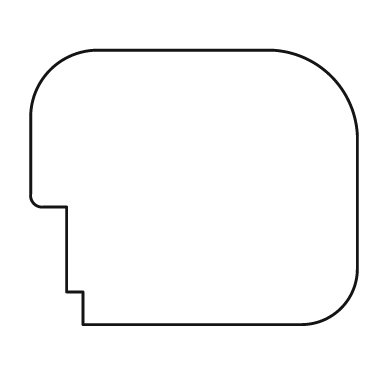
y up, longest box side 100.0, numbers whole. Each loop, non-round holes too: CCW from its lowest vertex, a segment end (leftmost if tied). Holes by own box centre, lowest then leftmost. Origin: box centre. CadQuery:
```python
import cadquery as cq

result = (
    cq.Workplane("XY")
    .moveTo(-34.0, -42.0)
    .lineTo(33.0, -42.0)
    .threePointArc((45.0, -37.0), (50.0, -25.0))
    .lineTo(50.0, 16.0)
    .threePointArc((42.0, 34.0), (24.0, 42.0))
    .lineTo(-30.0, 42.0)
    .threePointArc((-44.0, 36.0), (-50.0, 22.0))
    .lineTo(-50.0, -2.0)
    .threePointArc((-49.0, -5.0), (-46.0, -6.0))
    .lineTo(-39.0, -6.0)
    .lineTo(-39.0, -32.0)
    .lineTo(-34.0, -32.0)
    .close()
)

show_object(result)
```